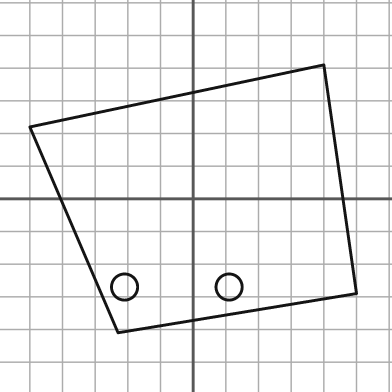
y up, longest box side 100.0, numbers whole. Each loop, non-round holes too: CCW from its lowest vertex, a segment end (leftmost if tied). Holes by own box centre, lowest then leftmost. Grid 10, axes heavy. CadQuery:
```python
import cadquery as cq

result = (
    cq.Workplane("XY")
    .moveTo(-23.0, -41.0)
    .lineTo(50.0, -29.0)
    .lineTo(40.0, 41.0)
    .lineTo(-50.0, 22.0)
    .close()
    .moveTo(-21.0, -27.0)
    .circle(4.0)
    .moveTo(11.0, -27.0)
    .circle(4.0)
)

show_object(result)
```